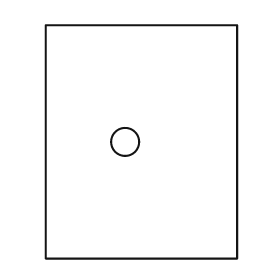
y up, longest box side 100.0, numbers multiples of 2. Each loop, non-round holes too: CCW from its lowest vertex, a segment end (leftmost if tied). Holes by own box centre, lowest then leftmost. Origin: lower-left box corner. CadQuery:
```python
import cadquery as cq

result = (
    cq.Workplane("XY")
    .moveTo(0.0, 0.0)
    .lineTo(82.0, 0.0)
    .lineTo(82.0, 100.0)
    .lineTo(0.0, 100.0)
    .close()
    .moveTo(34.0, 50.0)
    .circle(6.0)
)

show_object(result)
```